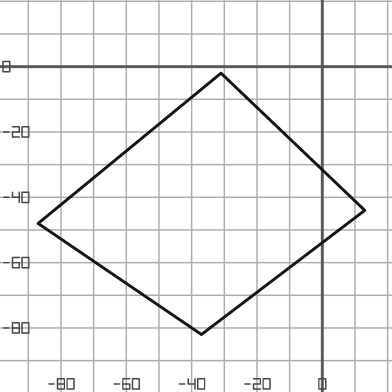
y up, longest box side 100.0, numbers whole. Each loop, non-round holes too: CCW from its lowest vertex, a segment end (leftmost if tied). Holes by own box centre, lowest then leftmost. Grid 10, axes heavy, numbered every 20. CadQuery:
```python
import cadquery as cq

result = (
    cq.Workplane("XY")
    .moveTo(-37.0, -82.0)
    .lineTo(13.0, -44.0)
    .lineTo(-31.0, -2.0)
    .lineTo(-87.0, -48.0)
    .close()
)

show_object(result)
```